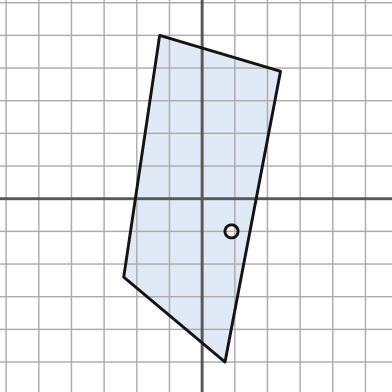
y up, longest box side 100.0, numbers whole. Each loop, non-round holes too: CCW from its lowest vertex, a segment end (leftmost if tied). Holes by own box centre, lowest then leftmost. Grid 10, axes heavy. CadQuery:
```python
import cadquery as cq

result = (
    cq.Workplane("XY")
    .moveTo(7.0, -50.0)
    .lineTo(24.0, 39.0)
    .lineTo(-13.0, 50.0)
    .lineTo(-24.0, -24.0)
    .close()
    .moveTo(9.0, -10.0)
    .circle(2.0)
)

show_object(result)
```